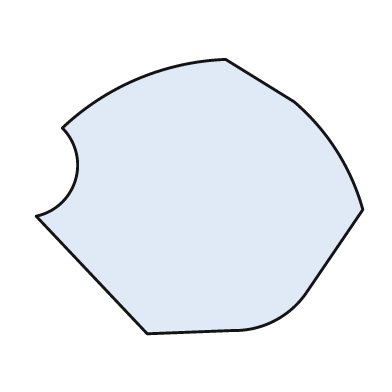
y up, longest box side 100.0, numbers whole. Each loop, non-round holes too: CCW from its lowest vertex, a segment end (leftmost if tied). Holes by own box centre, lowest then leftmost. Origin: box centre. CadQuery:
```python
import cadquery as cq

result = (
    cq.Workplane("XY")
    .moveTo(-16.0, -42.0)
    .lineTo(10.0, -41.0)
    .threePointArc((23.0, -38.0), (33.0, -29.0))
    .lineTo(50.0, -4.0)
    .threePointArc((42.0, 14.0), (29.0, 29.0))
    .lineTo(8.0, 42.0)
    .threePointArc((-19.0, 36.0), (-42.0, 21.0))
    .threePointArc((-38.0, 5.0), (-50.0, -6.0))
    .close()
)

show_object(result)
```